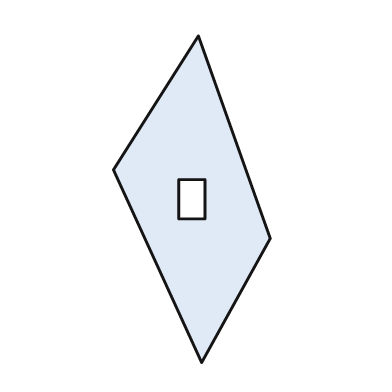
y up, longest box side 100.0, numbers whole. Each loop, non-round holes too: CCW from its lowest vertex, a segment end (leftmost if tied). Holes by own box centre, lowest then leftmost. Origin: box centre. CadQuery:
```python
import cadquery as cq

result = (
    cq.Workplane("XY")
    .moveTo(3.0, -50.0)
    .lineTo(24.0, -12.0)
    .lineTo(2.0, 50.0)
    .lineTo(-24.0, 9.0)
    .close()
    .moveTo(-4.0, -6.0)
    .lineTo(4.0, -6.0)
    .lineTo(4.0, 6.0)
    .lineTo(-4.0, 6.0)
    .close()
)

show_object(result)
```